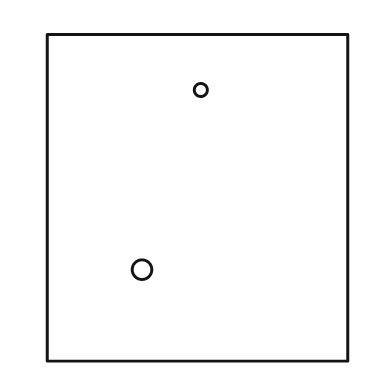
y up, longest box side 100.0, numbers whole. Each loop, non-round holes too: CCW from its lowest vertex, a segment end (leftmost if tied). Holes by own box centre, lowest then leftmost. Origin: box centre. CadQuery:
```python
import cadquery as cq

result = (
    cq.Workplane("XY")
    .moveTo(-46.0, -50.0)
    .lineTo(46.0, -50.0)
    .lineTo(46.0, 50.0)
    .lineTo(-46.0, 50.0)
    .close()
    .moveTo(-17.0, -22.0)
    .circle(3.0)
    .moveTo(1.0, 33.0)
    .circle(2.0)
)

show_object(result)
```